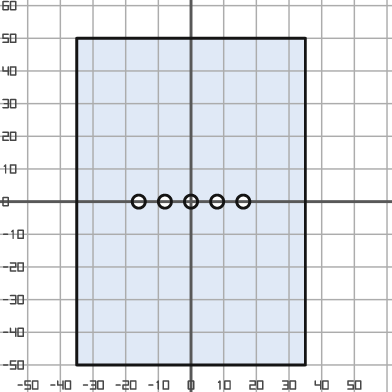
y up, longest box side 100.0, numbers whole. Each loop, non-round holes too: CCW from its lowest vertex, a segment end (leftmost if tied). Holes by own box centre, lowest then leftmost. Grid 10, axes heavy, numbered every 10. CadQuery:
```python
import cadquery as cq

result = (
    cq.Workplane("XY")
    .moveTo(-35.0, -50.0)
    .lineTo(35.0, -50.0)
    .lineTo(35.0, 50.0)
    .lineTo(-35.0, 50.0)
    .close()
    .moveTo(-16.0, 0.0)
    .circle(2.0)
    .moveTo(-8.0, 0.0)
    .circle(2.0)
    .moveTo(0.0, 0.0)
    .circle(2.0)
    .moveTo(8.0, 0.0)
    .circle(2.0)
    .moveTo(16.0, 0.0)
    .circle(2.0)
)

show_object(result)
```